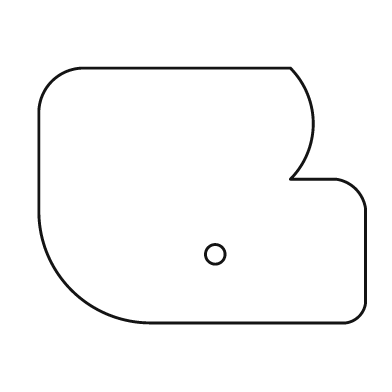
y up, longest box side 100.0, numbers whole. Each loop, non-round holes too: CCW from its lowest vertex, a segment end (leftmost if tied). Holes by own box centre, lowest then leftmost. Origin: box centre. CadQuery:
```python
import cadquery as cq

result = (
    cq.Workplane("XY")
    .moveTo(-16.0, -39.0)
    .lineTo(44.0, -39.0)
    .threePointArc((48.0, -37.0), (50.0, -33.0))
    .lineTo(50.0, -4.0)
    .threePointArc((47.0, 2.0), (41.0, 5.0))
    .lineTo(27.0, 5.0)
    .threePointArc((34.0, 22.0), (27.0, 39.0))
    .lineTo(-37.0, 39.0)
    .threePointArc((-46.0, 35.0), (-50.0, 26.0))
    .lineTo(-50.0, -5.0)
    .threePointArc((-40.0, -29.0), (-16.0, -39.0))
    .close()
    .moveTo(4.0, -18.0)
    .circle(3.0)
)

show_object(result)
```